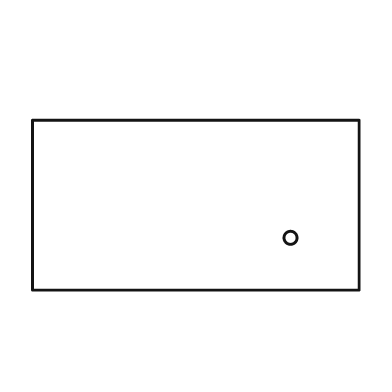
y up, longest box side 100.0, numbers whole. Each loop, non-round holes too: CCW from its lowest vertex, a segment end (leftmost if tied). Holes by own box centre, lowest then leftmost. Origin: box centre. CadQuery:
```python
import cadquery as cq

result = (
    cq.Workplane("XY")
    .moveTo(-50.0, -26.0)
    .lineTo(50.0, -26.0)
    .lineTo(50.0, 26.0)
    .lineTo(-50.0, 26.0)
    .close()
    .moveTo(29.0, -10.0)
    .circle(2.0)
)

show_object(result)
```